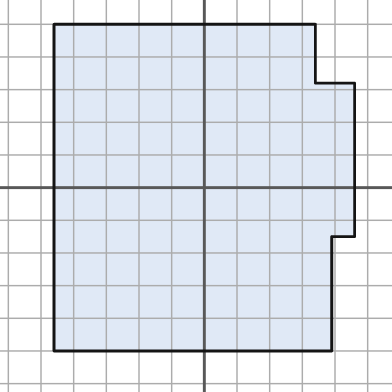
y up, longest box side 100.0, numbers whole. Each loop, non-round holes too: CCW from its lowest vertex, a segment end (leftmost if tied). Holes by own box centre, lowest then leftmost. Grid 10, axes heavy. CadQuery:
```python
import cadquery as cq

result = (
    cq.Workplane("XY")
    .moveTo(-46.0, -50.0)
    .lineTo(39.0, -50.0)
    .lineTo(39.0, -15.0)
    .lineTo(46.0, -15.0)
    .lineTo(46.0, 32.0)
    .lineTo(34.0, 32.0)
    .lineTo(34.0, 50.0)
    .lineTo(-46.0, 50.0)
    .close()
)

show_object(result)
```